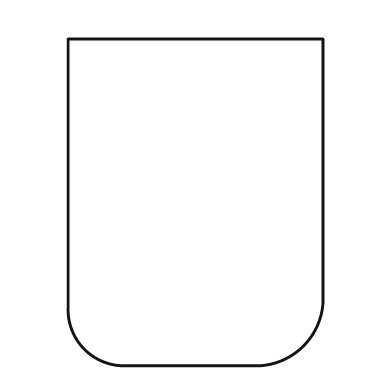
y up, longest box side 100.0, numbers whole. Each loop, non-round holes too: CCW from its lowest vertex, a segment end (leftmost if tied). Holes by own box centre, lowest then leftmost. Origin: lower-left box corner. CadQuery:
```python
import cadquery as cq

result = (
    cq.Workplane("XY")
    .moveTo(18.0, 0.0)
    .lineTo(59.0, 0.0)
    .threePointArc((72.0, 6.0), (78.0, 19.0))
    .lineTo(78.0, 100.0)
    .lineTo(0.0, 100.0)
    .lineTo(0.0, 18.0)
    .threePointArc((5.0, 5.0), (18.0, 0.0))
    .close()
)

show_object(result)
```